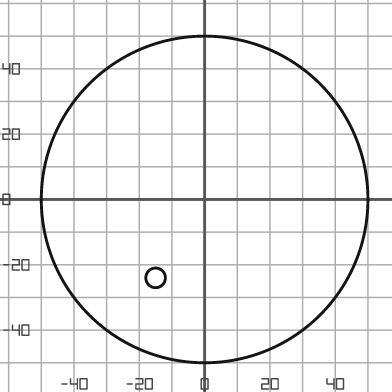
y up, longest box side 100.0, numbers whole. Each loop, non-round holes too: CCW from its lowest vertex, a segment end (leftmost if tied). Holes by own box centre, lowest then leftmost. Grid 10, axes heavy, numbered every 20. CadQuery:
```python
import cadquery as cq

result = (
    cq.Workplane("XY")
    .moveTo(0.0, 0.0)
    .circle(50.0)
    .moveTo(-15.0, -24.0)
    .circle(3.0)
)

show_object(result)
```